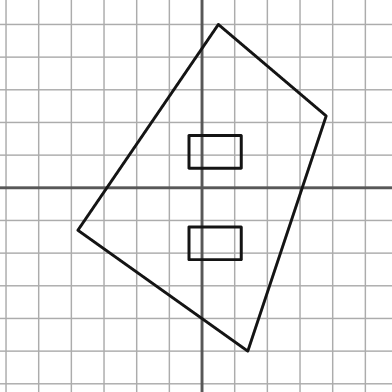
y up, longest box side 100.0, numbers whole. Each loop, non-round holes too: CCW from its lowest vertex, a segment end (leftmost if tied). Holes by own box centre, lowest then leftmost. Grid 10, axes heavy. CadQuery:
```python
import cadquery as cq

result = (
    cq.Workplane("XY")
    .moveTo(14.0, -50.0)
    .lineTo(38.0, 22.0)
    .lineTo(5.0, 50.0)
    .lineTo(-38.0, -13.0)
    .close()
    .moveTo(-4.0, -22.0)
    .lineTo(12.0, -22.0)
    .lineTo(12.0, -12.0)
    .lineTo(-4.0, -12.0)
    .close()
    .moveTo(-4.0, 6.0)
    .lineTo(12.0, 6.0)
    .lineTo(12.0, 16.0)
    .lineTo(-4.0, 16.0)
    .close()
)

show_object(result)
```